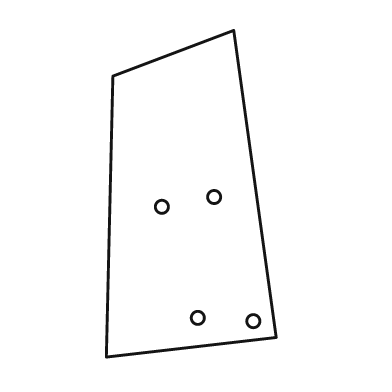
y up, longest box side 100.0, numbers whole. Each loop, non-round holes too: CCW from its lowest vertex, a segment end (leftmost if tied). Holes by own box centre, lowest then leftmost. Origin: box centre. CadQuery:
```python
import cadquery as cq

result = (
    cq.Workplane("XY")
    .moveTo(-26.0, -50.0)
    .lineTo(26.0, -44.0)
    .lineTo(13.0, 50.0)
    .lineTo(-24.0, 36.0)
    .close()
    .moveTo(19.0, -39.0)
    .circle(2.0)
    .moveTo(2.0, -38.0)
    .circle(2.0)
    .moveTo(-9.0, -4.0)
    .circle(2.0)
    .moveTo(7.0, -1.0)
    .circle(2.0)
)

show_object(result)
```